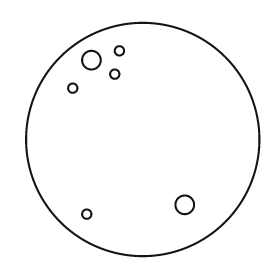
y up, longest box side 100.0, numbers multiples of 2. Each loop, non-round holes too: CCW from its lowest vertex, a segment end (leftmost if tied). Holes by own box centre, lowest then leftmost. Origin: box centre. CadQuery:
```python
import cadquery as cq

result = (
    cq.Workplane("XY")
    .moveTo(0.0, 0.0)
    .circle(50.0)
    .moveTo(-24.0, -32.0)
    .circle(2.0)
    .moveTo(18.0, -28.0)
    .circle(4.0)
    .moveTo(-30.0, 22.0)
    .circle(2.0)
    .moveTo(-12.0, 28.0)
    .circle(2.0)
    .moveTo(-22.0, 34.0)
    .circle(4.0)
    .moveTo(-10.0, 38.0)
    .circle(2.0)
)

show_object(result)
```